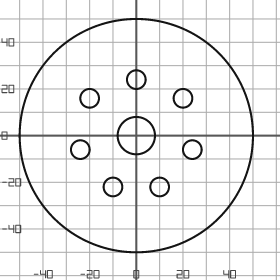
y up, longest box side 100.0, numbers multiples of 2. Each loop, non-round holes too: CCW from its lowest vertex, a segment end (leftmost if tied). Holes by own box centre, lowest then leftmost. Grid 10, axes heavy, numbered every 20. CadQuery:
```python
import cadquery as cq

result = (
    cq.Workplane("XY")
    .moveTo(0.0, 0.0)
    .circle(50.0)
    .moveTo(-10.0, -22.0)
    .circle(4.0)
    .moveTo(10.0, -22.0)
    .circle(4.0)
    .moveTo(-24.0, -6.0)
    .circle(4.0)
    .moveTo(24.0, -6.0)
    .circle(4.0)
    .moveTo(0.0, 0.0)
    .circle(8.0)
    .moveTo(-20.0, 16.0)
    .circle(4.0)
    .moveTo(20.0, 16.0)
    .circle(4.0)
    .moveTo(0.0, 24.0)
    .circle(4.0)
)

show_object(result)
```